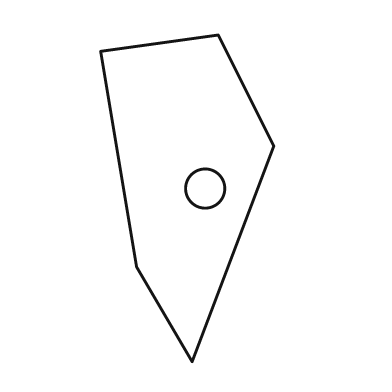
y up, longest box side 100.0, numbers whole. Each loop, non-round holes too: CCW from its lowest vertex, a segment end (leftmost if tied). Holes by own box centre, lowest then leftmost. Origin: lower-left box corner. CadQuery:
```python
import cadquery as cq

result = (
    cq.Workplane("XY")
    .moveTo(28.0, 0.0)
    .lineTo(53.0, 66.0)
    .lineTo(36.0, 100.0)
    .lineTo(0.0, 95.0)
    .lineTo(11.0, 29.0)
    .close()
    .moveTo(32.0, 53.0)
    .circle(6.0)
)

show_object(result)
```